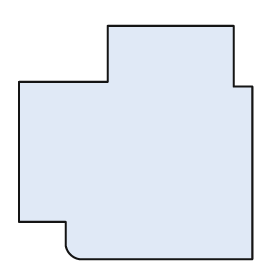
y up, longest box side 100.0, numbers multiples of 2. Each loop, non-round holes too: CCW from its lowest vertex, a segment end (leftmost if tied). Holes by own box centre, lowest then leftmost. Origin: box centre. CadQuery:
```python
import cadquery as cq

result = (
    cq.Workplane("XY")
    .moveTo(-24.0, -50.0)
    .lineTo(50.0, -50.0)
    .lineTo(50.0, 24.0)
    .lineTo(42.0, 24.0)
    .lineTo(42.0, 50.0)
    .lineTo(-12.0, 50.0)
    .lineTo(-12.0, 26.0)
    .lineTo(-50.0, 26.0)
    .lineTo(-50.0, -34.0)
    .lineTo(-30.0, -34.0)
    .lineTo(-30.0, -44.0)
    .threePointArc((-28.0, -48.0), (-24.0, -50.0))
    .close()
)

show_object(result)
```